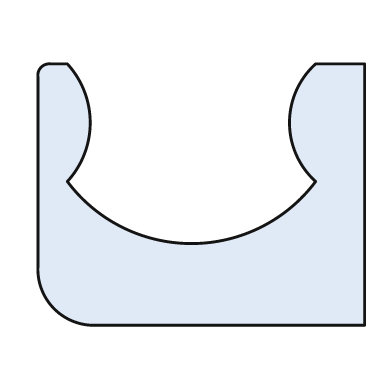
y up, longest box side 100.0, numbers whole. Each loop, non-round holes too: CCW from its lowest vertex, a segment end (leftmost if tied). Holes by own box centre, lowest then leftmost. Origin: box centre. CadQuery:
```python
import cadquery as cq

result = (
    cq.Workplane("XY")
    .moveTo(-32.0, -40.0)
    .lineTo(50.0, -40.0)
    .lineTo(50.0, 40.0)
    .lineTo(35.0, 40.0)
    .threePointArc((27.0, 22.0), (35.0, 4.0))
    .threePointArc((-3.0, -15.0), (-41.0, 4.0))
    .threePointArc((-34.0, 22.0), (-41.0, 40.0))
    .lineTo(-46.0, 40.0)
    .threePointArc((-49.0, 39.0), (-50.0, 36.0))
    .lineTo(-50.0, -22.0)
    .threePointArc((-45.0, -35.0), (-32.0, -40.0))
    .close()
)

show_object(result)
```